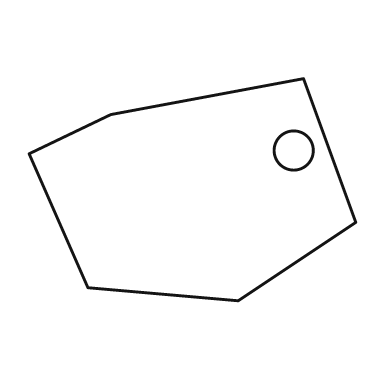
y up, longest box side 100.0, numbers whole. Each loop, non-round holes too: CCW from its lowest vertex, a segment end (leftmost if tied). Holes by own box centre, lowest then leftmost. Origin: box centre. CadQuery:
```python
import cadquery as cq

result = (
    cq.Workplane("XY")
    .moveTo(14.0, -34.0)
    .lineTo(50.0, -10.0)
    .lineTo(34.0, 34.0)
    .lineTo(-25.0, 23.0)
    .lineTo(-50.0, 11.0)
    .lineTo(-32.0, -30.0)
    .close()
    .moveTo(31.0, 12.0)
    .circle(6.0)
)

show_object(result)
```